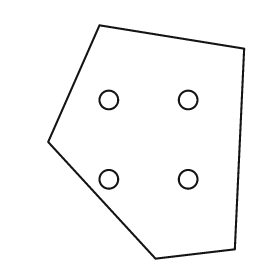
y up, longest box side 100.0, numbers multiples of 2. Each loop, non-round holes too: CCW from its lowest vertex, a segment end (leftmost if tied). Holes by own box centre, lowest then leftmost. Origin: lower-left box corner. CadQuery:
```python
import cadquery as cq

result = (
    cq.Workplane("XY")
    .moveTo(46.0, 0.0)
    .lineTo(80.0, 4.0)
    .lineTo(84.0, 90.0)
    .lineTo(22.0, 100.0)
    .lineTo(0.0, 50.0)
    .close()
    .moveTo(26.0, 34.0)
    .circle(4.0)
    .moveTo(60.0, 34.0)
    .circle(4.0)
    .moveTo(26.0, 68.0)
    .circle(4.0)
    .moveTo(60.0, 68.0)
    .circle(4.0)
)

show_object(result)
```